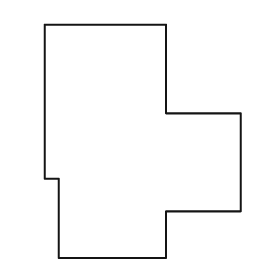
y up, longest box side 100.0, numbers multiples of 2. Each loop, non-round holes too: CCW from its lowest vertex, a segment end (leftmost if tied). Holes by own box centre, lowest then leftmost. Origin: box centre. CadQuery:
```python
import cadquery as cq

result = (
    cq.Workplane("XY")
    .moveTo(-36.0, -50.0)
    .lineTo(10.0, -50.0)
    .lineTo(10.0, -30.0)
    .lineTo(42.0, -30.0)
    .lineTo(42.0, 12.0)
    .lineTo(10.0, 12.0)
    .lineTo(10.0, 50.0)
    .lineTo(-42.0, 50.0)
    .lineTo(-42.0, -16.0)
    .lineTo(-36.0, -16.0)
    .close()
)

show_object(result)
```